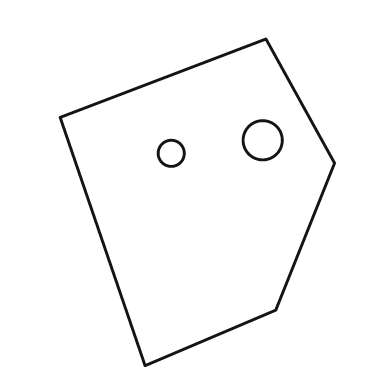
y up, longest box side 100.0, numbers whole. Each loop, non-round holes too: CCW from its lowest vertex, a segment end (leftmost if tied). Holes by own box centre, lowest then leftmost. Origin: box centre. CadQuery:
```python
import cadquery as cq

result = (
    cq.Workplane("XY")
    .moveTo(-16.0, -50.0)
    .lineTo(24.0, -33.0)
    .lineTo(42.0, 12.0)
    .lineTo(21.0, 50.0)
    .lineTo(-42.0, 26.0)
    .close()
    .moveTo(-8.0, 15.0)
    .circle(4.0)
    .moveTo(20.0, 19.0)
    .circle(6.0)
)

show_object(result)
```